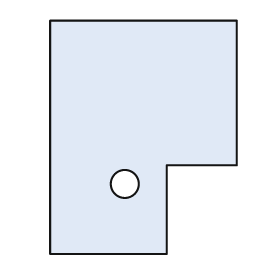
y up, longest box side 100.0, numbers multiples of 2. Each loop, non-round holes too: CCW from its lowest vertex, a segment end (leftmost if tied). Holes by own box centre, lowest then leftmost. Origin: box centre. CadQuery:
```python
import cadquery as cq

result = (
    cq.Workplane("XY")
    .moveTo(-40.0, -50.0)
    .lineTo(10.0, -50.0)
    .lineTo(10.0, -12.0)
    .lineTo(40.0, -12.0)
    .lineTo(40.0, 50.0)
    .lineTo(-40.0, 50.0)
    .close()
    .moveTo(-8.0, -20.0)
    .circle(6.0)
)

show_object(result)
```